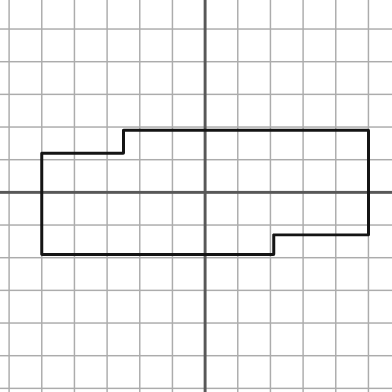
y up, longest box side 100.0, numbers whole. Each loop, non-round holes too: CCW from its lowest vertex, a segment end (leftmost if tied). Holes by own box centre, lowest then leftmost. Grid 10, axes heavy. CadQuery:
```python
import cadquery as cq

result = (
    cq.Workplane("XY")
    .moveTo(-50.0, -19.0)
    .lineTo(21.0, -19.0)
    .lineTo(21.0, -13.0)
    .lineTo(50.0, -13.0)
    .lineTo(50.0, 19.0)
    .lineTo(-25.0, 19.0)
    .lineTo(-25.0, 12.0)
    .lineTo(-50.0, 12.0)
    .close()
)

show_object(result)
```